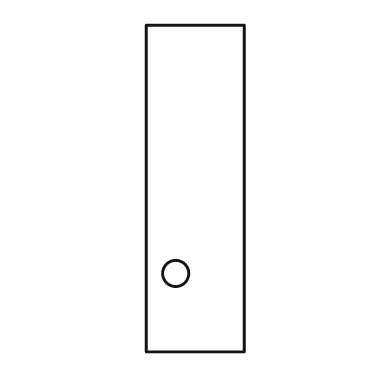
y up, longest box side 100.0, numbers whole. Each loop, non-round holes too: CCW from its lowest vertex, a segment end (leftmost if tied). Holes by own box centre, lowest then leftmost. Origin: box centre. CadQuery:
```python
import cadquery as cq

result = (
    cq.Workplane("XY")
    .moveTo(-15.0, -50.0)
    .lineTo(15.0, -50.0)
    .lineTo(15.0, 50.0)
    .lineTo(-15.0, 50.0)
    .close()
    .moveTo(-6.0, -26.0)
    .circle(4.0)
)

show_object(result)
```